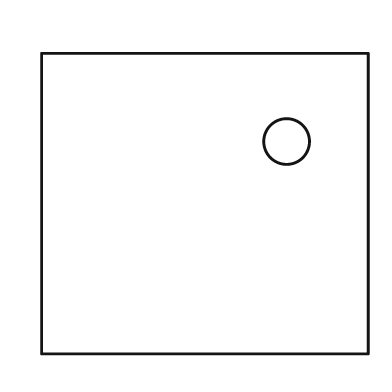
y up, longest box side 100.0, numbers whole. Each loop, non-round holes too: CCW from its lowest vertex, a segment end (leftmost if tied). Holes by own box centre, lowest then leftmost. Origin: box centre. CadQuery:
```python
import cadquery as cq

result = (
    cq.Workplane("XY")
    .moveTo(-50.0, -46.0)
    .lineTo(50.0, -46.0)
    .lineTo(50.0, 46.0)
    .lineTo(-50.0, 46.0)
    .close()
    .moveTo(25.0, 19.0)
    .circle(7.0)
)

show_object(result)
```